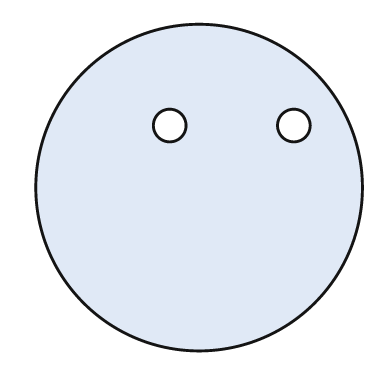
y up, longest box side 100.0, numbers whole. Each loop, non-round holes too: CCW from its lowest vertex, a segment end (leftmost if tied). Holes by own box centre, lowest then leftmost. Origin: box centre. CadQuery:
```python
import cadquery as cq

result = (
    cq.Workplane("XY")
    .moveTo(0.0, 0.0)
    .circle(50.0)
    .moveTo(-9.0, 19.0)
    .circle(5.0)
    .moveTo(29.0, 19.0)
    .circle(5.0)
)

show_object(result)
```